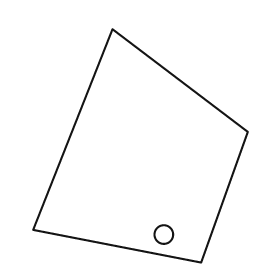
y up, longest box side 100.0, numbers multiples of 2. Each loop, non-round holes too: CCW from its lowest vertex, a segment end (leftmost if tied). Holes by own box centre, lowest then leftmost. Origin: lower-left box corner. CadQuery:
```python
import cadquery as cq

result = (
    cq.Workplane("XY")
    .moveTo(72.0, 0.0)
    .lineTo(92.0, 56.0)
    .lineTo(34.0, 100.0)
    .lineTo(0.0, 14.0)
    .close()
    .moveTo(56.0, 12.0)
    .circle(4.0)
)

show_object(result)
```